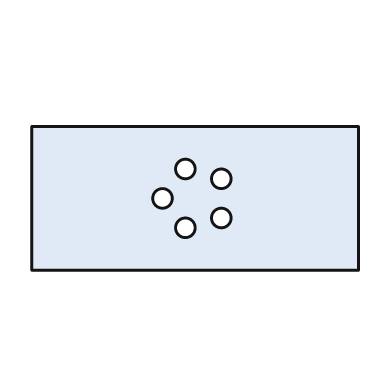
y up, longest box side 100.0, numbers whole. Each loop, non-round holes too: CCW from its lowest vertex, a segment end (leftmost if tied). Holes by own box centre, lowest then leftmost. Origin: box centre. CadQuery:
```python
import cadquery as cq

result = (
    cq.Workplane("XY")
    .moveTo(-50.0, -22.0)
    .lineTo(50.0, -22.0)
    .lineTo(50.0, 22.0)
    .lineTo(-50.0, 22.0)
    .close()
    .moveTo(-3.0, -9.0)
    .circle(3.0)
    .moveTo(8.0, -6.0)
    .circle(3.0)
    .moveTo(-10.0, 0.0)
    .circle(3.0)
    .moveTo(8.0, 6.0)
    .circle(3.0)
    .moveTo(-3.0, 9.0)
    .circle(3.0)
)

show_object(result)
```